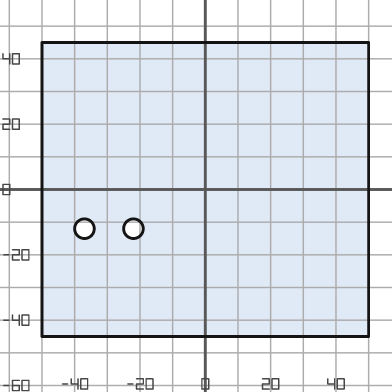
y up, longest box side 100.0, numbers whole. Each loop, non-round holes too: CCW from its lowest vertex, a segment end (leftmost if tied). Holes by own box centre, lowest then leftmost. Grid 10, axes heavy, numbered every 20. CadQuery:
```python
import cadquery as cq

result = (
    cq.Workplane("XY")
    .moveTo(-50.0, -45.0)
    .lineTo(50.0, -45.0)
    .lineTo(50.0, 45.0)
    .lineTo(-50.0, 45.0)
    .close()
    .moveTo(-37.0, -12.0)
    .circle(3.0)
    .moveTo(-22.0, -12.0)
    .circle(3.0)
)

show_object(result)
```